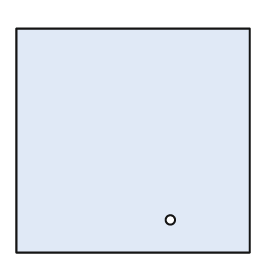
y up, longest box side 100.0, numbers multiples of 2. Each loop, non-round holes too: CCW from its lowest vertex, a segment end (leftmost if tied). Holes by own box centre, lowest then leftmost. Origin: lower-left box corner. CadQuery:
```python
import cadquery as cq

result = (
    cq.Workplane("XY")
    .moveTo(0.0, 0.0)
    .lineTo(100.0, 0.0)
    .lineTo(100.0, 96.0)
    .lineTo(0.0, 96.0)
    .close()
    .moveTo(66.0, 14.0)
    .circle(2.0)
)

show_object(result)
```